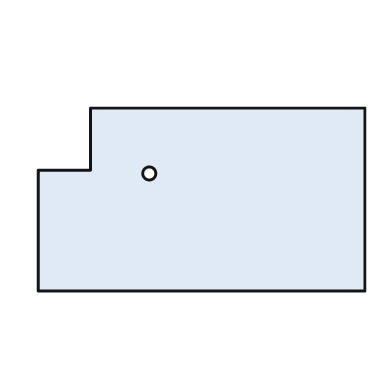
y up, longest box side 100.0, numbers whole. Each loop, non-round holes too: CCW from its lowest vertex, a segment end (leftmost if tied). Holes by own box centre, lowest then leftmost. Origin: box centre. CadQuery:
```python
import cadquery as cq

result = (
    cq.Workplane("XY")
    .moveTo(-50.0, -28.0)
    .lineTo(50.0, -28.0)
    .lineTo(50.0, 28.0)
    .lineTo(-34.0, 28.0)
    .lineTo(-34.0, 9.0)
    .lineTo(-50.0, 9.0)
    .close()
    .moveTo(-16.0, 8.0)
    .circle(2.0)
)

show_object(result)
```